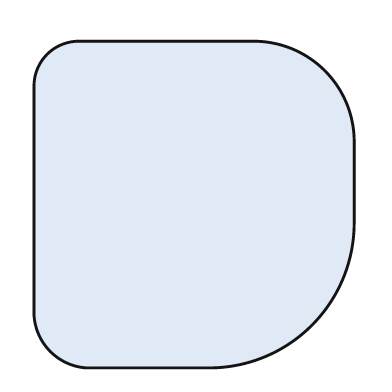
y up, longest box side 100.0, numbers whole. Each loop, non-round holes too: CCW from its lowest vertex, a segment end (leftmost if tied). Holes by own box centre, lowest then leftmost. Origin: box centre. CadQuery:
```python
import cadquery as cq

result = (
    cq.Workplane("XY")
    .moveTo(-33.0, -50.0)
    .lineTo(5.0, -50.0)
    .threePointArc((36.0, -37.0), (49.0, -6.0))
    .lineTo(49.0, 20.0)
    .threePointArc((40.0, 41.0), (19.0, 50.0))
    .lineTo(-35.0, 50.0)
    .threePointArc((-45.0, 46.0), (-49.0, 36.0))
    .lineTo(-49.0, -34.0)
    .threePointArc((-44.0, -45.0), (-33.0, -50.0))
    .close()
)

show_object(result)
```